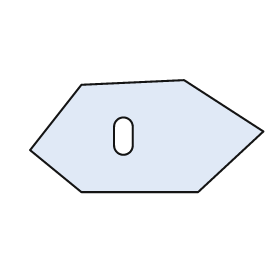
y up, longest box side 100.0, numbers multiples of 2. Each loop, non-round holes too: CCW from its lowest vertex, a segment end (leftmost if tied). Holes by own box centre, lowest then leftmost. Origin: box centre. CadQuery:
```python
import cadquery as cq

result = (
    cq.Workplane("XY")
    .moveTo(-28.0, -24.0)
    .lineTo(22.0, -24.0)
    .lineTo(50.0, 2.0)
    .lineTo(16.0, 24.0)
    .lineTo(-28.0, 22.0)
    .lineTo(-50.0, -6.0)
    .close()
    .moveTo(-14.0, -4.0)
    .threePointArc((-10.0, -8.0), (-6.0, -4.0))
    .lineTo(-6.0, 4.0)
    .threePointArc((-10.0, 8.0), (-14.0, 4.0))
    .close()
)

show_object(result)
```